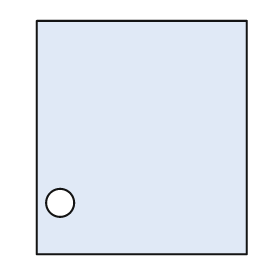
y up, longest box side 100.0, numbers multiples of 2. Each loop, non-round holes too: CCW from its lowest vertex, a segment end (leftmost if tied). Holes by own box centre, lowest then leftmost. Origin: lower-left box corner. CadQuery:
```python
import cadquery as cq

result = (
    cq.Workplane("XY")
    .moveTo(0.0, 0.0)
    .lineTo(90.0, 0.0)
    .lineTo(90.0, 100.0)
    .lineTo(0.0, 100.0)
    .close()
    .moveTo(10.0, 22.0)
    .circle(6.0)
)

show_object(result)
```